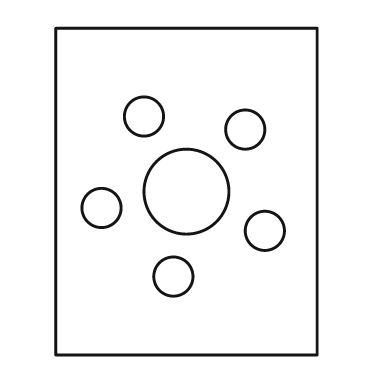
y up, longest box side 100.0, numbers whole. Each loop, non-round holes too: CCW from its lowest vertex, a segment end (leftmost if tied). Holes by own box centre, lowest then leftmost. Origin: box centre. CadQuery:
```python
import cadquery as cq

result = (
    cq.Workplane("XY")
    .moveTo(-40.0, -50.0)
    .lineTo(40.0, -50.0)
    .lineTo(40.0, 50.0)
    .lineTo(-40.0, 50.0)
    .close()
    .moveTo(-4.0, -26.0)
    .circle(6.0)
    .moveTo(24.0, -12.0)
    .circle(6.0)
    .moveTo(-26.0, -5.0)
    .circle(6.0)
    .moveTo(0.0, 0.0)
    .circle(13.0)
    .moveTo(18.0, 19.0)
    .circle(6.0)
    .moveTo(-13.0, 23.0)
    .circle(6.0)
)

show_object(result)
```